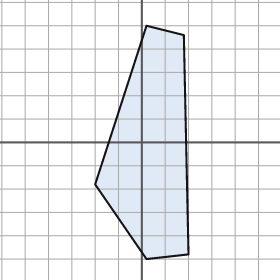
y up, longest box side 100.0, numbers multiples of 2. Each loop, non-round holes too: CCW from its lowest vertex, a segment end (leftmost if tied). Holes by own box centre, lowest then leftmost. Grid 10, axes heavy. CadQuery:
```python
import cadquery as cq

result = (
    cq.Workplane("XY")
    .moveTo(2.0, -50.0)
    .lineTo(20.0, -48.0)
    .lineTo(18.0, 46.0)
    .lineTo(2.0, 50.0)
    .lineTo(-20.0, -18.0)
    .close()
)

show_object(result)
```